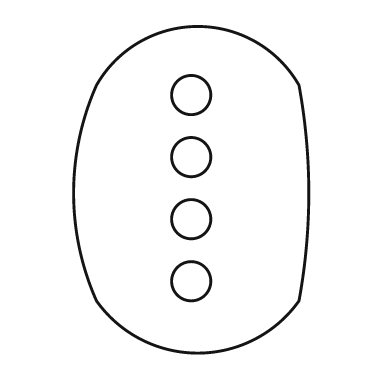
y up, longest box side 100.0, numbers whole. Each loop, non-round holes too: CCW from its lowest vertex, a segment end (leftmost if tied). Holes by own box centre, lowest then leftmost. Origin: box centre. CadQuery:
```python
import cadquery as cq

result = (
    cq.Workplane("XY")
    .moveTo(-29.0, -34.0)
    .threePointArc((2.0, -50.0), (33.0, -34.0))
    .threePointArc((36.0, -1.0), (33.0, 32.0))
    .threePointArc((2.0, 50.0), (-29.0, 32.0))
    .threePointArc((-36.0, -1.0), (-29.0, -34.0))
    .close()
    .moveTo(0.0, -28.0)
    .circle(6.0)
    .moveTo(0.0, -9.0)
    .circle(6.0)
    .moveTo(0.0, 10.0)
    .circle(6.0)
    .moveTo(0.0, 29.0)
    .circle(6.0)
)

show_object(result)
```